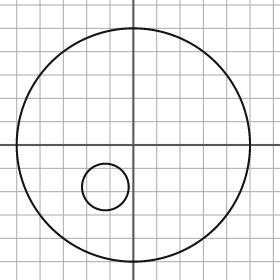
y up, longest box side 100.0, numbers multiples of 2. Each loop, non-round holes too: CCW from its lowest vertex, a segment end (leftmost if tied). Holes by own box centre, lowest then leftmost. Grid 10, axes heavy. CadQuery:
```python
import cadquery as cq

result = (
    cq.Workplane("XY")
    .moveTo(0.0, 0.0)
    .circle(50.0)
    .moveTo(-12.0, -18.0)
    .circle(10.0)
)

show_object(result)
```